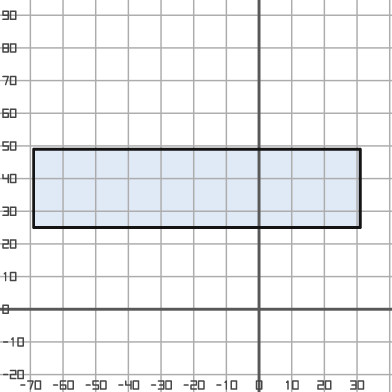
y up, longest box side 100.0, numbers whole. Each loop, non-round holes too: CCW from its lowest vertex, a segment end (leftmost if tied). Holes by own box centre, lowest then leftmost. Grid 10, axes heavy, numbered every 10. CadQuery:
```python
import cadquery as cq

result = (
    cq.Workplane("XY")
    .moveTo(-69.0, 25.0)
    .lineTo(31.0, 25.0)
    .lineTo(31.0, 49.0)
    .lineTo(-69.0, 49.0)
    .close()
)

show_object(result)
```